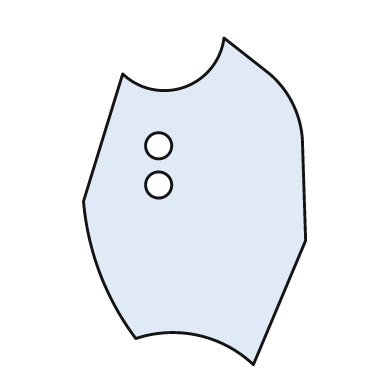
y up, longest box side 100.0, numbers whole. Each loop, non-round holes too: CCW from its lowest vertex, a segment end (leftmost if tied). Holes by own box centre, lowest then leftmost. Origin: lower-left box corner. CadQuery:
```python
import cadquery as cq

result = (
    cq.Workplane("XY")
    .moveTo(52.0, 0.0)
    .lineTo(68.0, 38.0)
    .lineTo(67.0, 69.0)
    .threePointArc((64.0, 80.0), (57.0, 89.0))
    .lineTo(43.0, 100.0)
    .threePointArc((31.0, 85.0), (12.0, 89.0))
    .lineTo(0.0, 50.0)
    .threePointArc((5.0, 28.0), (16.0, 8.0))
    .threePointArc((35.0, 9.0), (52.0, 0.0))
    .close()
    .moveTo(23.0, 55.0)
    .circle(4.0)
    .moveTo(23.0, 67.0)
    .circle(4.0)
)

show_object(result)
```